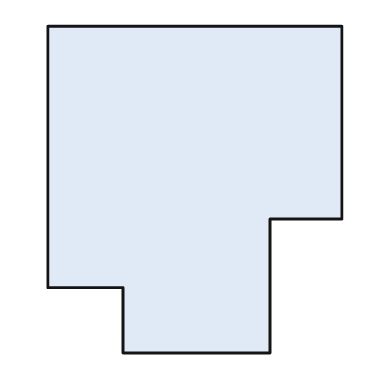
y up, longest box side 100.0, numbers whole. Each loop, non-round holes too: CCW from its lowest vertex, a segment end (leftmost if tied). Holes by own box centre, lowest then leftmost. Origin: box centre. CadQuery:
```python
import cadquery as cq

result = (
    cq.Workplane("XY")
    .moveTo(-22.0, -50.0)
    .lineTo(23.0, -50.0)
    .lineTo(23.0, -9.0)
    .lineTo(45.0, -9.0)
    .lineTo(45.0, 50.0)
    .lineTo(-45.0, 50.0)
    .lineTo(-45.0, -30.0)
    .lineTo(-22.0, -30.0)
    .close()
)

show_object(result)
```